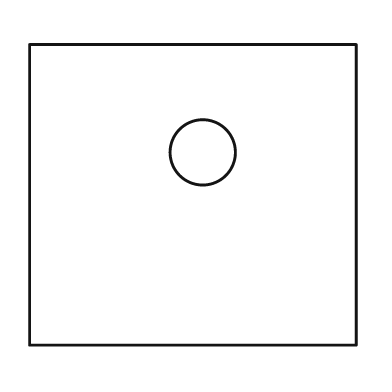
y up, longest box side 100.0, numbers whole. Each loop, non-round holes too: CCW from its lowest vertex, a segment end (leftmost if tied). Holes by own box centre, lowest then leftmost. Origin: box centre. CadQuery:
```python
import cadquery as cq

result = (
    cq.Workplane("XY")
    .moveTo(-50.0, -46.0)
    .lineTo(50.0, -46.0)
    .lineTo(50.0, 46.0)
    .lineTo(-50.0, 46.0)
    .close()
    .moveTo(3.0, 13.0)
    .circle(10.0)
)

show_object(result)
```